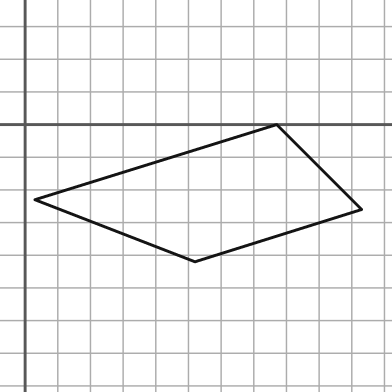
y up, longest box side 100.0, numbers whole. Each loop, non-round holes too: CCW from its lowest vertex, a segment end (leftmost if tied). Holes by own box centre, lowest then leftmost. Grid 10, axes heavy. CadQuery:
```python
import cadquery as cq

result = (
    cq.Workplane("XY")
    .moveTo(52.0, -42.0)
    .lineTo(103.0, -26.0)
    .lineTo(77.0, 0.0)
    .lineTo(3.0, -23.0)
    .close()
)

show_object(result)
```